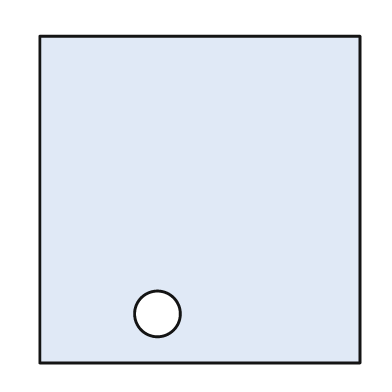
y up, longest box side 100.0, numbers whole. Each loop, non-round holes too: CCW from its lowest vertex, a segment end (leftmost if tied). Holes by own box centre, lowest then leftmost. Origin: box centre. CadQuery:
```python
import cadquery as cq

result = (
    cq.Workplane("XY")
    .moveTo(-49.0, -50.0)
    .lineTo(49.0, -50.0)
    .lineTo(49.0, 50.0)
    .lineTo(-49.0, 50.0)
    .close()
    .moveTo(-13.0, -35.0)
    .circle(7.0)
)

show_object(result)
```